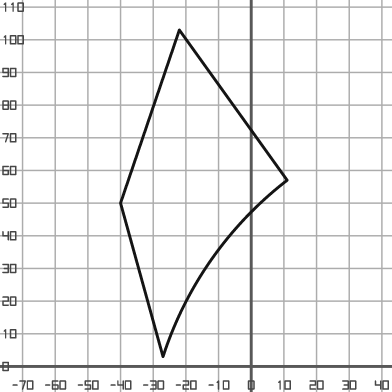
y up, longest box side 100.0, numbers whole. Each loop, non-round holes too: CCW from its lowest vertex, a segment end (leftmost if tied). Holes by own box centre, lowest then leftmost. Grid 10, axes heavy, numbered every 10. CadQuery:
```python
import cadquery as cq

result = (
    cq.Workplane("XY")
    .moveTo(-27.0, 3.0)
    .threePointArc((-12.0, 33.0), (11.0, 57.0))
    .lineTo(-22.0, 103.0)
    .lineTo(-40.0, 50.0)
    .close()
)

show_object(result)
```